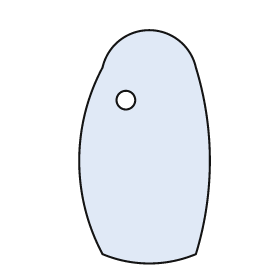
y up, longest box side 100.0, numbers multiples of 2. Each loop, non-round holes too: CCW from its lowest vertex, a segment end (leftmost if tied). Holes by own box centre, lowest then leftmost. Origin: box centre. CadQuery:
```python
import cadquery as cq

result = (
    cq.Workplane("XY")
    .moveTo(-18.0, -46.0)
    .threePointArc((2.0, -50.0), (22.0, -46.0))
    .threePointArc((28.0, -6.0), (22.0, 34.0))
    .threePointArc((2.0, 50.0), (-18.0, 34.0))
    .threePointArc((-28.0, -6.0), (-18.0, -46.0))
    .close()
    .moveTo(-8.0, 20.0)
    .circle(4.0)
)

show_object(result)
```